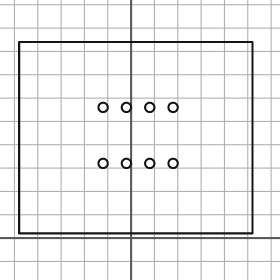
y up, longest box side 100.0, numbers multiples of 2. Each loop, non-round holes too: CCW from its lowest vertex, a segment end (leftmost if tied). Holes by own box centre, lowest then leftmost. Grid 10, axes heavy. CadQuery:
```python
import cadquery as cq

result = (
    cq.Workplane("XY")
    .moveTo(-48.0, 2.0)
    .lineTo(52.0, 2.0)
    .lineTo(52.0, 84.0)
    .lineTo(-48.0, 84.0)
    .close()
    .moveTo(-12.0, 32.0)
    .circle(2.0)
    .moveTo(-2.0, 32.0)
    .circle(2.0)
    .moveTo(8.0, 32.0)
    .circle(2.0)
    .moveTo(18.0, 32.0)
    .circle(2.0)
    .moveTo(-12.0, 56.0)
    .circle(2.0)
    .moveTo(-2.0, 56.0)
    .circle(2.0)
    .moveTo(8.0, 56.0)
    .circle(2.0)
    .moveTo(18.0, 56.0)
    .circle(2.0)
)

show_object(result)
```